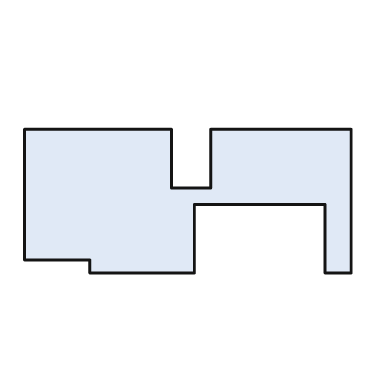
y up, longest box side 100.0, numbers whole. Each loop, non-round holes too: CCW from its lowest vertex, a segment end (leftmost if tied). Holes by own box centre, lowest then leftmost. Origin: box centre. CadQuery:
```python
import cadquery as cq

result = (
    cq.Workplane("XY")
    .moveTo(-30.0, -22.0)
    .lineTo(2.0, -22.0)
    .lineTo(2.0, -1.0)
    .lineTo(42.0, -1.0)
    .lineTo(42.0, -22.0)
    .lineTo(50.0, -22.0)
    .lineTo(50.0, 22.0)
    .lineTo(7.0, 22.0)
    .lineTo(7.0, 4.0)
    .lineTo(-5.0, 4.0)
    .lineTo(-5.0, 22.0)
    .lineTo(-50.0, 22.0)
    .lineTo(-50.0, -18.0)
    .lineTo(-30.0, -18.0)
    .close()
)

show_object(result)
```